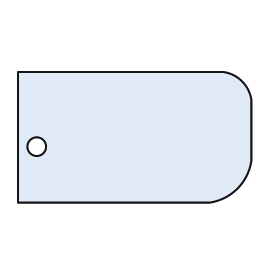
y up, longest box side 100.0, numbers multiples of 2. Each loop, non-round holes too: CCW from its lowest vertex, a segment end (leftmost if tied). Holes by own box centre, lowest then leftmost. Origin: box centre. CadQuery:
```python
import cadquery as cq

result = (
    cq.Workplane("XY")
    .moveTo(-50.0, -28.0)
    .lineTo(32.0, -28.0)
    .threePointArc((44.0, -22.0), (50.0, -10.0))
    .lineTo(50.0, 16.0)
    .threePointArc((46.0, 24.0), (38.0, 28.0))
    .lineTo(-50.0, 28.0)
    .close()
    .moveTo(-42.0, -4.0)
    .circle(4.0)
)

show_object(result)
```